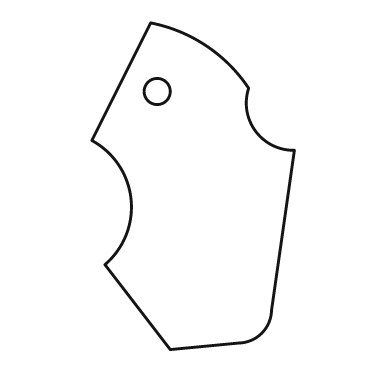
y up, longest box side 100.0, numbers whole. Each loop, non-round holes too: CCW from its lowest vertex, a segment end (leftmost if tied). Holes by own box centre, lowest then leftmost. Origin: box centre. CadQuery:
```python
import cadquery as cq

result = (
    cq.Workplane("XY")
    .moveTo(-7.0, -50.0)
    .lineTo(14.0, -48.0)
    .threePointArc((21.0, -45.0), (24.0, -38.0))
    .lineTo(31.0, 11.0)
    .threePointArc((19.0, 17.0), (17.0, 30.0))
    .threePointArc((4.0, 43.0), (-13.0, 50.0))
    .lineTo(-31.0, 14.0)
    .threePointArc((-19.0, -4.0), (-27.0, -24.0))
    .close()
    .moveTo(-11.0, 29.0)
    .circle(4.0)
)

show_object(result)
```